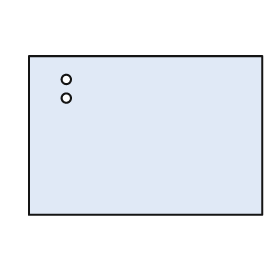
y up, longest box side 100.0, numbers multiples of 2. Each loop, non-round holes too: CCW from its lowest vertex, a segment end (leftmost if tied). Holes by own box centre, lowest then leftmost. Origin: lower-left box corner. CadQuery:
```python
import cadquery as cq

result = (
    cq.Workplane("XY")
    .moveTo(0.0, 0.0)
    .lineTo(100.0, 0.0)
    .lineTo(100.0, 68.0)
    .lineTo(0.0, 68.0)
    .close()
    .moveTo(16.0, 50.0)
    .circle(2.0)
    .moveTo(16.0, 58.0)
    .circle(2.0)
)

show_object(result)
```